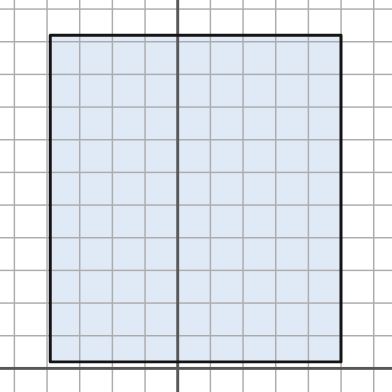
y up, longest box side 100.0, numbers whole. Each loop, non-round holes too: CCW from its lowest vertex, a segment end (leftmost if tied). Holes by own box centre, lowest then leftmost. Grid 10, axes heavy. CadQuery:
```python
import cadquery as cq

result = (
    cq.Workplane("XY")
    .moveTo(-39.0, 2.0)
    .lineTo(50.0, 2.0)
    .lineTo(50.0, 102.0)
    .lineTo(-39.0, 102.0)
    .close()
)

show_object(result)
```